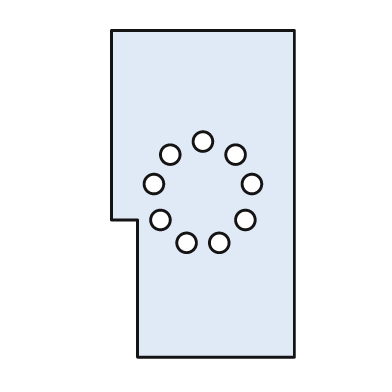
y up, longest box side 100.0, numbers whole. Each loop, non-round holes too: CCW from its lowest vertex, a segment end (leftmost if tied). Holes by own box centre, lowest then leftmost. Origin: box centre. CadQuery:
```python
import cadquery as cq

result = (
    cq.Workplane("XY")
    .moveTo(-20.0, -50.0)
    .lineTo(28.0, -50.0)
    .lineTo(28.0, 50.0)
    .lineTo(-28.0, 50.0)
    .lineTo(-28.0, -8.0)
    .lineTo(-20.0, -8.0)
    .close()
    .moveTo(-5.0, -15.0)
    .circle(3.0)
    .moveTo(5.0, -15.0)
    .circle(3.0)
    .moveTo(-13.0, -8.0)
    .circle(3.0)
    .moveTo(13.0, -8.0)
    .circle(3.0)
    .moveTo(-15.0, 3.0)
    .circle(3.0)
    .moveTo(15.0, 3.0)
    .circle(3.0)
    .moveTo(-10.0, 12.0)
    .circle(3.0)
    .moveTo(10.0, 12.0)
    .circle(3.0)
    .moveTo(0.0, 16.0)
    .circle(3.0)
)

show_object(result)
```